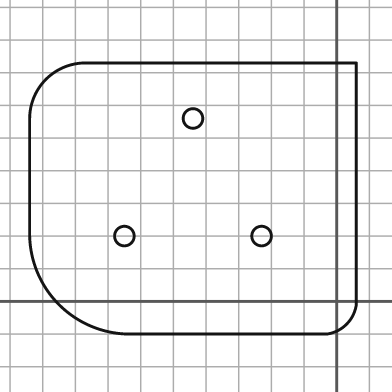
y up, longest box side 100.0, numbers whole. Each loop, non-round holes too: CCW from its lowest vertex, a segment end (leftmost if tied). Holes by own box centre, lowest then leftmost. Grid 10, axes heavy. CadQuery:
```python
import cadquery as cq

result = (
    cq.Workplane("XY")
    .moveTo(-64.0, -10.0)
    .lineTo(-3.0, -10.0)
    .threePointArc((3.0, -7.0), (6.0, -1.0))
    .lineTo(6.0, 73.0)
    .lineTo(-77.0, 73.0)
    .threePointArc((-89.0, 68.0), (-94.0, 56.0))
    .lineTo(-94.0, 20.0)
    .threePointArc((-85.0, -1.0), (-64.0, -10.0))
    .close()
    .moveTo(-65.0, 20.0)
    .circle(3.0)
    .moveTo(-23.0, 20.0)
    .circle(3.0)
    .moveTo(-44.0, 56.0)
    .circle(3.0)
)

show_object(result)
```